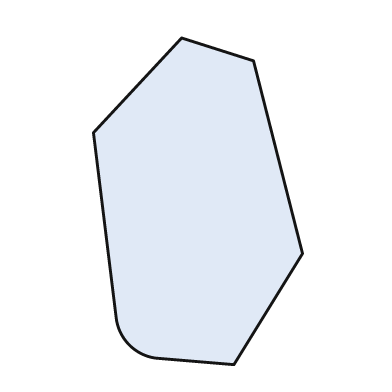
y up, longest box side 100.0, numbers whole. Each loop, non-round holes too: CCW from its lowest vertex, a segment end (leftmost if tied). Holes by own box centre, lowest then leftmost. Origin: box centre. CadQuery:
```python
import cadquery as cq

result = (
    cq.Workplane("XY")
    .moveTo(11.0, -50.0)
    .lineTo(32.0, -16.0)
    .lineTo(17.0, 43.0)
    .lineTo(-5.0, 50.0)
    .lineTo(-32.0, 21.0)
    .lineTo(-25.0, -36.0)
    .threePointArc((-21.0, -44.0), (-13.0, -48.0))
    .close()
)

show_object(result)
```